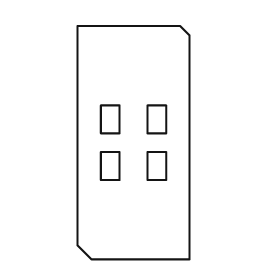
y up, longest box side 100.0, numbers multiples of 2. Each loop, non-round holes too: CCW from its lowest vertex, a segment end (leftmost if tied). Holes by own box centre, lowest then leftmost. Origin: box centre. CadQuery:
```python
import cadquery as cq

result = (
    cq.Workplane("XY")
    .moveTo(-18.0, -50.0)
    .lineTo(24.0, -50.0)
    .lineTo(24.0, 46.0)
    .lineTo(20.0, 50.0)
    .lineTo(-24.0, 50.0)
    .lineTo(-24.0, -44.0)
    .close()
    .moveTo(-14.0, -16.0)
    .lineTo(-6.0, -16.0)
    .lineTo(-6.0, -4.0)
    .lineTo(-14.0, -4.0)
    .close()
    .moveTo(6.0, -16.0)
    .lineTo(14.0, -16.0)
    .lineTo(14.0, -4.0)
    .lineTo(6.0, -4.0)
    .close()
    .moveTo(-14.0, 4.0)
    .lineTo(-6.0, 4.0)
    .lineTo(-6.0, 16.0)
    .lineTo(-14.0, 16.0)
    .close()
    .moveTo(6.0, 4.0)
    .lineTo(14.0, 4.0)
    .lineTo(14.0, 16.0)
    .lineTo(6.0, 16.0)
    .close()
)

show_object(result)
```